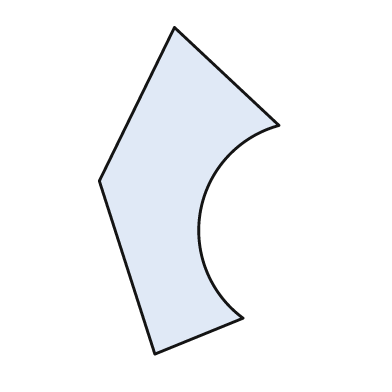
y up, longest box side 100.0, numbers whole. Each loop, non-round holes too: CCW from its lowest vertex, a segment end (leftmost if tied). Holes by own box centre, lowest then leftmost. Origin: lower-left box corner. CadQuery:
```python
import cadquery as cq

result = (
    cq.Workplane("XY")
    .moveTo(17.0, 0.0)
    .lineTo(44.0, 11.0)
    .threePointArc((31.0, 44.0), (55.0, 70.0))
    .lineTo(23.0, 100.0)
    .lineTo(0.0, 53.0)
    .close()
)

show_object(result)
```